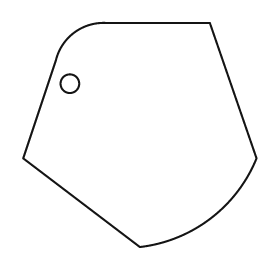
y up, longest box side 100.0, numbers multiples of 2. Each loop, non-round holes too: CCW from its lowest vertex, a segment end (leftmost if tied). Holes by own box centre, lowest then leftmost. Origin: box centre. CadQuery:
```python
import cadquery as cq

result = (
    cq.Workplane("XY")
    .moveTo(0.0, -48.0)
    .threePointArc((30.0, -36.0), (50.0, -10.0))
    .lineTo(30.0, 48.0)
    .lineTo(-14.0, 48.0)
    .threePointArc((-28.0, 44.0), (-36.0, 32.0))
    .lineTo(-50.0, -10.0)
    .close()
    .moveTo(-30.0, 22.0)
    .circle(4.0)
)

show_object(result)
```